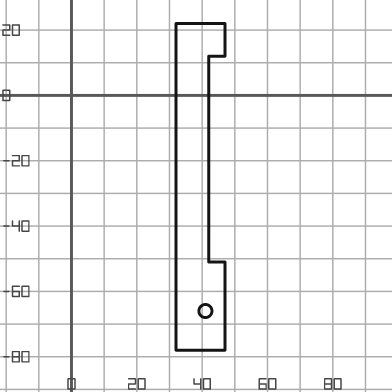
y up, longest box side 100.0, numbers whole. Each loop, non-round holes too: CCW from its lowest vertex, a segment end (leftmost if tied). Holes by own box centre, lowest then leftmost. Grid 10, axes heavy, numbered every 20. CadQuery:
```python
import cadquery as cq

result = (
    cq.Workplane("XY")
    .moveTo(32.0, -78.0)
    .lineTo(47.0, -78.0)
    .lineTo(47.0, -51.0)
    .lineTo(42.0, -51.0)
    .lineTo(42.0, 12.0)
    .lineTo(47.0, 12.0)
    .lineTo(47.0, 22.0)
    .lineTo(32.0, 22.0)
    .close()
    .moveTo(41.0, -66.0)
    .circle(2.0)
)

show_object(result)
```